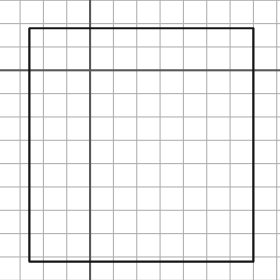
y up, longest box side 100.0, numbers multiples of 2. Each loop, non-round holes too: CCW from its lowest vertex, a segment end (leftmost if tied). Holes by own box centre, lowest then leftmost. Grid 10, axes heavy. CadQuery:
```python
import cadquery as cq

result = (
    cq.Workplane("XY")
    .moveTo(-26.0, -82.0)
    .lineTo(70.0, -82.0)
    .lineTo(70.0, 18.0)
    .lineTo(-26.0, 18.0)
    .close()
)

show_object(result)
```